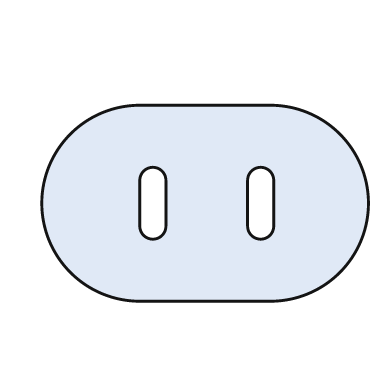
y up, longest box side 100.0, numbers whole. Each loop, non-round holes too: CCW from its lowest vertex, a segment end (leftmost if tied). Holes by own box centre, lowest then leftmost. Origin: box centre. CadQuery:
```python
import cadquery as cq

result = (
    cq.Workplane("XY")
    .moveTo(-20.0, -30.0)
    .lineTo(20.0, -30.0)
    .threePointArc((50.0, 0.0), (20.0, 30.0))
    .lineTo(-20.0, 30.0)
    .threePointArc((-50.0, 0.0), (-20.0, -30.0))
    .close()
    .moveTo(-20.0, -7.0)
    .threePointArc((-16.0, -11.0), (-12.0, -7.0))
    .lineTo(-12.0, 7.0)
    .threePointArc((-16.0, 11.0), (-20.0, 7.0))
    .close()
    .moveTo(13.0, -7.0)
    .threePointArc((17.0, -11.0), (21.0, -7.0))
    .lineTo(21.0, 7.0)
    .threePointArc((17.0, 11.0), (13.0, 7.0))
    .close()
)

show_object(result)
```